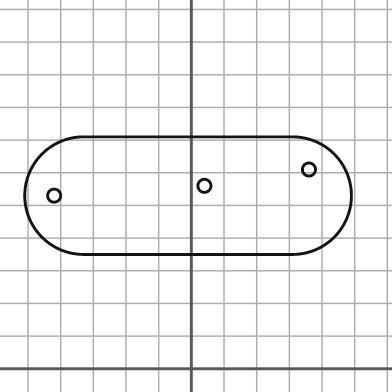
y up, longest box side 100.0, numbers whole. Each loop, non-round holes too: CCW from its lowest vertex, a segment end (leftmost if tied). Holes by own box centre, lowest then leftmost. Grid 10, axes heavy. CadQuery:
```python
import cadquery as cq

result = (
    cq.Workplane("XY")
    .moveTo(-33.0, 35.0)
    .lineTo(31.0, 35.0)
    .threePointArc((49.0, 53.0), (31.0, 71.0))
    .lineTo(-33.0, 71.0)
    .threePointArc((-51.0, 53.0), (-33.0, 35.0))
    .close()
    .moveTo(-42.0, 53.0)
    .circle(2.0)
    .moveTo(4.0, 56.0)
    .circle(2.0)
    .moveTo(36.0, 61.0)
    .circle(2.0)
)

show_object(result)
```